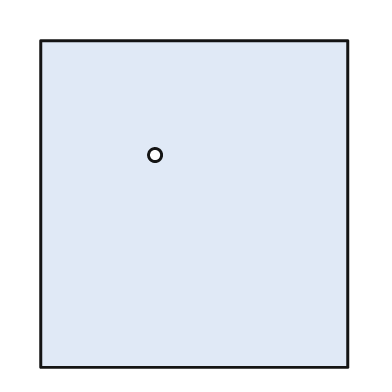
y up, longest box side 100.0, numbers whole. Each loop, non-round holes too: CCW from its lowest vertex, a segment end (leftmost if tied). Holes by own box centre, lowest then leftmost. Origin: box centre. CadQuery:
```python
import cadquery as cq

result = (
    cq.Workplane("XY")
    .moveTo(-47.0, -50.0)
    .lineTo(47.0, -50.0)
    .lineTo(47.0, 50.0)
    .lineTo(-47.0, 50.0)
    .close()
    .moveTo(-12.0, 15.0)
    .circle(2.0)
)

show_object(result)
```